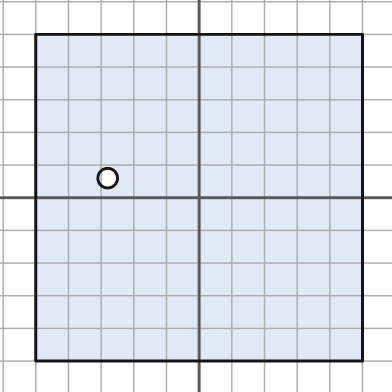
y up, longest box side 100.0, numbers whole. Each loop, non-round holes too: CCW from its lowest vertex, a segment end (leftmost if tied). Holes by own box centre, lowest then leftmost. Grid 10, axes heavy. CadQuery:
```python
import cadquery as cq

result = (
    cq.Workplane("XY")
    .moveTo(-50.0, -50.0)
    .lineTo(50.0, -50.0)
    .lineTo(50.0, 50.0)
    .lineTo(-50.0, 50.0)
    .close()
    .moveTo(-28.0, 6.0)
    .circle(3.0)
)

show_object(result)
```